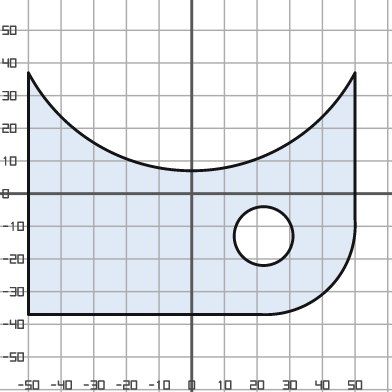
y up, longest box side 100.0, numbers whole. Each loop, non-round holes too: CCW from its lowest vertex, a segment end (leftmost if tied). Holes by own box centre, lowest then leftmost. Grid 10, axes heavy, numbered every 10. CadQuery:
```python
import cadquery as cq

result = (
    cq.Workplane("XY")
    .moveTo(-50.0, -37.0)
    .lineTo(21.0, -37.0)
    .threePointArc((42.0, -29.0), (50.0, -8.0))
    .lineTo(50.0, 37.0)
    .threePointArc((0.0, 7.0), (-50.0, 37.0))
    .close()
    .moveTo(22.0, -13.0)
    .circle(9.0)
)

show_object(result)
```